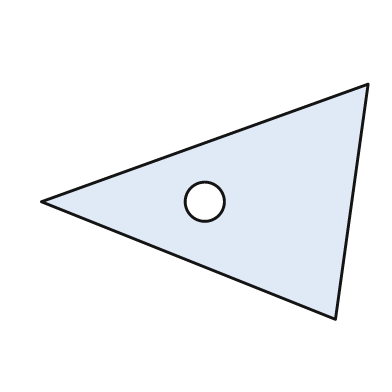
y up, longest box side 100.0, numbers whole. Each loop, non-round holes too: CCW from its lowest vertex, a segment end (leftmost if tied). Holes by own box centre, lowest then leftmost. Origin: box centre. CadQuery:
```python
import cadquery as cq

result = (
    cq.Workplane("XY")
    .moveTo(40.0, -36.0)
    .lineTo(50.0, 36.0)
    .lineTo(-50.0, 0.0)
    .close()
    .moveTo(0.0, 0.0)
    .circle(6.0)
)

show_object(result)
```